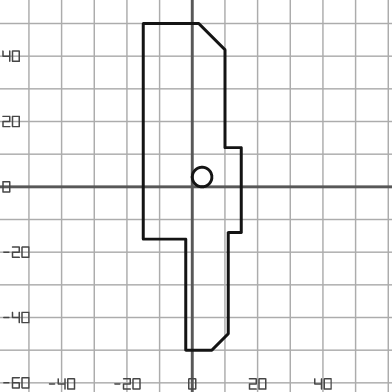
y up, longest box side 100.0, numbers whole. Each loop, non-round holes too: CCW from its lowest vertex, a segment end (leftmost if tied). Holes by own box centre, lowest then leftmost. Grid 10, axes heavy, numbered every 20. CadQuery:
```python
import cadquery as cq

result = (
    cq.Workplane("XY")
    .moveTo(-2.0, -50.0)
    .lineTo(6.0, -50.0)
    .lineTo(11.0, -45.0)
    .lineTo(11.0, -14.0)
    .lineTo(15.0, -14.0)
    .lineTo(15.0, 12.0)
    .lineTo(10.0, 12.0)
    .lineTo(10.0, 42.0)
    .lineTo(2.0, 50.0)
    .lineTo(-15.0, 50.0)
    .lineTo(-15.0, -16.0)
    .lineTo(-2.0, -16.0)
    .close()
    .moveTo(3.0, 3.0)
    .circle(3.0)
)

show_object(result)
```